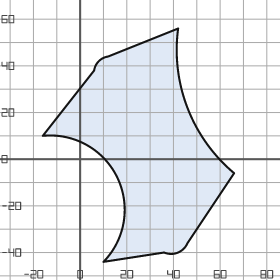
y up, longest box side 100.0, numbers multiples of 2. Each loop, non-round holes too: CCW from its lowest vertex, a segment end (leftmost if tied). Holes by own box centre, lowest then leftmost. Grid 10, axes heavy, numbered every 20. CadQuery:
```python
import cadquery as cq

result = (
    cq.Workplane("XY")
    .moveTo(10.0, -44.0)
    .lineTo(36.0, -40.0)
    .threePointArc((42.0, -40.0), (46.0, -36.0))
    .lineTo(66.0, -6.0)
    .threePointArc((46.0, 22.0), (42.0, 56.0))
    .lineTo(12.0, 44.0)
    .threePointArc((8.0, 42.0), (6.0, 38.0))
    .lineTo(-16.0, 10.0)
    .threePointArc((16.0, -8.0), (10.0, -44.0))
    .close()
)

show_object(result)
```